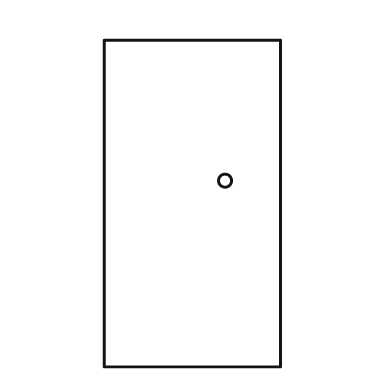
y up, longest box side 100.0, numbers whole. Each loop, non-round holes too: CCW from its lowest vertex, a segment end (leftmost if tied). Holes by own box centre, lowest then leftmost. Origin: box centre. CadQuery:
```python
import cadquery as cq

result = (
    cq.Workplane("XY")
    .moveTo(-27.0, -50.0)
    .lineTo(27.0, -50.0)
    .lineTo(27.0, 50.0)
    .lineTo(-27.0, 50.0)
    .close()
    .moveTo(10.0, 7.0)
    .circle(2.0)
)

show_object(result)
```